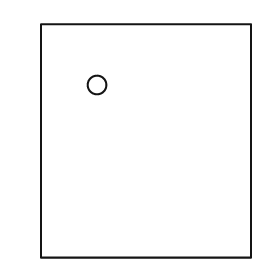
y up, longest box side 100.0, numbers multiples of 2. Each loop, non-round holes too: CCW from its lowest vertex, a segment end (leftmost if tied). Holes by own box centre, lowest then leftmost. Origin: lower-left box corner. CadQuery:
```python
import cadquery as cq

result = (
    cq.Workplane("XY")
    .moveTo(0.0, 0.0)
    .lineTo(90.0, 0.0)
    .lineTo(90.0, 100.0)
    .lineTo(0.0, 100.0)
    .close()
    .moveTo(24.0, 74.0)
    .circle(4.0)
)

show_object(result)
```